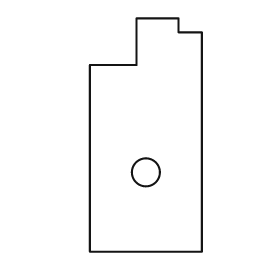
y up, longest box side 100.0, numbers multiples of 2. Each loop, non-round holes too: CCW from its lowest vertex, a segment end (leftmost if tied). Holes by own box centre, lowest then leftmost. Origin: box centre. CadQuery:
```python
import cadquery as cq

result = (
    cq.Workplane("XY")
    .moveTo(-24.0, -50.0)
    .lineTo(24.0, -50.0)
    .lineTo(24.0, 44.0)
    .lineTo(14.0, 44.0)
    .lineTo(14.0, 50.0)
    .lineTo(-4.0, 50.0)
    .lineTo(-4.0, 30.0)
    .lineTo(-24.0, 30.0)
    .close()
    .moveTo(0.0, -16.0)
    .circle(6.0)
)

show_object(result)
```